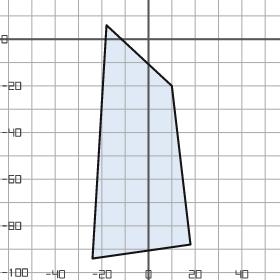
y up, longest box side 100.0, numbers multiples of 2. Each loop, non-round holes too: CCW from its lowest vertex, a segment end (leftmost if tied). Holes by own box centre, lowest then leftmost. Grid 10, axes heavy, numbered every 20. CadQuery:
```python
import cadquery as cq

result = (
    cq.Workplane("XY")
    .moveTo(-24.0, -94.0)
    .lineTo(18.0, -88.0)
    .lineTo(10.0, -20.0)
    .lineTo(-18.0, 6.0)
    .close()
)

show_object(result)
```